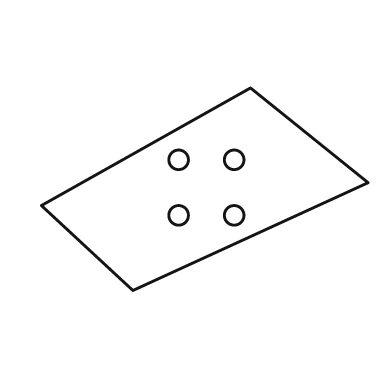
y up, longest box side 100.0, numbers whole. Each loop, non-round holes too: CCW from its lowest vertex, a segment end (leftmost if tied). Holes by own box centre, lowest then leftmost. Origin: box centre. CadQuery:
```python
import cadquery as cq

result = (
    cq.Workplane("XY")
    .moveTo(-22.0, -31.0)
    .lineTo(50.0, 2.0)
    .lineTo(14.0, 31.0)
    .lineTo(-50.0, -5.0)
    .close()
    .moveTo(-8.0, -8.0)
    .circle(3.0)
    .moveTo(9.0, -8.0)
    .circle(3.0)
    .moveTo(-8.0, 9.0)
    .circle(3.0)
    .moveTo(9.0, 9.0)
    .circle(3.0)
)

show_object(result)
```